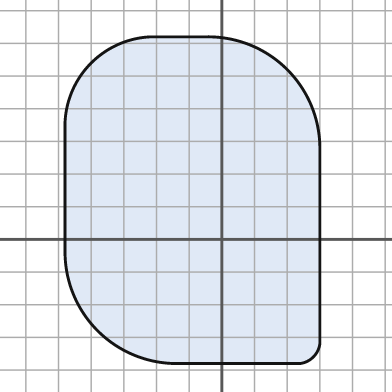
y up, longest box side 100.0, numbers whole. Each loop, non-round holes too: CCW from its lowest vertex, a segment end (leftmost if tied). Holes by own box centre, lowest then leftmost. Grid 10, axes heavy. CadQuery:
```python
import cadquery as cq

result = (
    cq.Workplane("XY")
    .moveTo(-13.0, -38.0)
    .lineTo(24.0, -38.0)
    .threePointArc((28.0, -36.0), (30.0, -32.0))
    .lineTo(30.0, 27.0)
    .threePointArc((20.0, 52.0), (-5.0, 62.0))
    .lineTo(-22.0, 62.0)
    .threePointArc((-40.0, 54.0), (-48.0, 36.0))
    .lineTo(-48.0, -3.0)
    .threePointArc((-38.0, -28.0), (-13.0, -38.0))
    .close()
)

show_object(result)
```